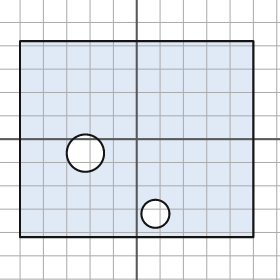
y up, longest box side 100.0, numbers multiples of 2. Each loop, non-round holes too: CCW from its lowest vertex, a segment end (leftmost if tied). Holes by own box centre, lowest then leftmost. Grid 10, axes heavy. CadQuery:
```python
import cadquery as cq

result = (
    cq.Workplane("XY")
    .moveTo(-50.0, -42.0)
    .lineTo(50.0, -42.0)
    .lineTo(50.0, 42.0)
    .lineTo(-50.0, 42.0)
    .close()
    .moveTo(8.0, -32.0)
    .circle(6.0)
    .moveTo(-22.0, -6.0)
    .circle(8.0)
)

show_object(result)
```